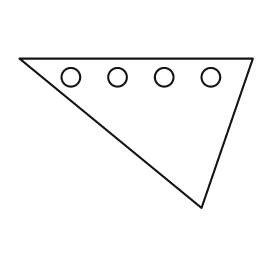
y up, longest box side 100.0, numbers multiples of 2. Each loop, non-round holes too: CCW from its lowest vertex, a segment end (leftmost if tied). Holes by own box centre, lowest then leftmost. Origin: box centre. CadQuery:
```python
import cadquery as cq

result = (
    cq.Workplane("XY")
    .moveTo(28.0, -32.0)
    .lineTo(50.0, 32.0)
    .lineTo(-50.0, 32.0)
    .close()
    .moveTo(-28.0, 24.0)
    .circle(4.0)
    .moveTo(-8.0, 24.0)
    .circle(4.0)
    .moveTo(12.0, 24.0)
    .circle(4.0)
    .moveTo(32.0, 24.0)
    .circle(4.0)
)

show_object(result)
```